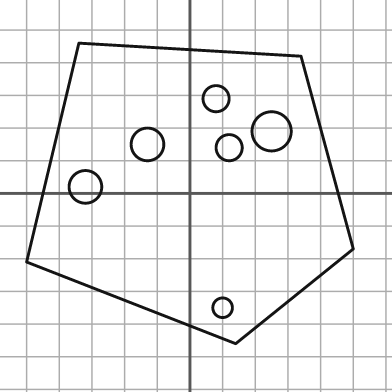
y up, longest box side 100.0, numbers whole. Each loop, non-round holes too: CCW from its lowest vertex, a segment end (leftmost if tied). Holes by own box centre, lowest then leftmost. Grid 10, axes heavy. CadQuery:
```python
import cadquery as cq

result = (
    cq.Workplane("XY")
    .moveTo(14.0, -46.0)
    .lineTo(50.0, -17.0)
    .lineTo(34.0, 42.0)
    .lineTo(-34.0, 46.0)
    .lineTo(-50.0, -21.0)
    .close()
    .moveTo(10.0, -35.0)
    .circle(3.0)
    .moveTo(-32.0, 2.0)
    .circle(5.0)
    .moveTo(12.0, 14.0)
    .circle(4.0)
    .moveTo(-13.0, 15.0)
    .circle(5.0)
    .moveTo(25.0, 19.0)
    .circle(6.0)
    .moveTo(8.0, 29.0)
    .circle(4.0)
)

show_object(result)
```